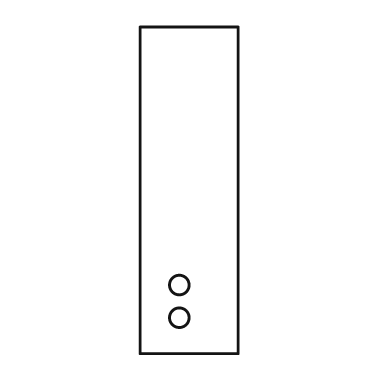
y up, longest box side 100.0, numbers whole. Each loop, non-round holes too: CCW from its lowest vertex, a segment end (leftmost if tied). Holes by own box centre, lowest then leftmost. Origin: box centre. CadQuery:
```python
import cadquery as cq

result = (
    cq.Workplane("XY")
    .moveTo(-15.0, -50.0)
    .lineTo(15.0, -50.0)
    .lineTo(15.0, 50.0)
    .lineTo(-15.0, 50.0)
    .close()
    .moveTo(-3.0, -39.0)
    .circle(3.0)
    .moveTo(-3.0, -29.0)
    .circle(3.0)
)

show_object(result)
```